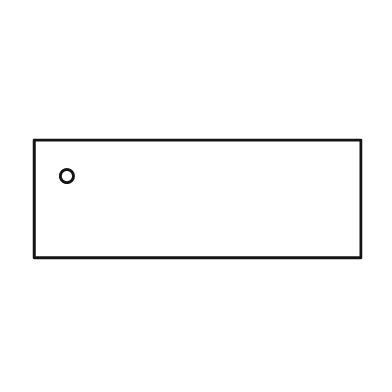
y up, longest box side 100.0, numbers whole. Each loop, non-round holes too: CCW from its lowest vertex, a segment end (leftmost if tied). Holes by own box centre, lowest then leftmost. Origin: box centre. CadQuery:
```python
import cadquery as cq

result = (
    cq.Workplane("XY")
    .moveTo(-50.0, -18.0)
    .lineTo(50.0, -18.0)
    .lineTo(50.0, 18.0)
    .lineTo(-50.0, 18.0)
    .close()
    .moveTo(-40.0, 7.0)
    .circle(2.0)
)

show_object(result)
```